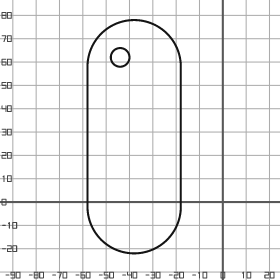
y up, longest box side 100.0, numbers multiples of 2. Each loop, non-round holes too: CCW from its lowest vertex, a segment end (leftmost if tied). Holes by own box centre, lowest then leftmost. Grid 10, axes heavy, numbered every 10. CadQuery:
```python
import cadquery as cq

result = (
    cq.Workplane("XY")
    .moveTo(-58.0, -2.0)
    .threePointArc((-38.0, -22.0), (-18.0, -2.0))
    .lineTo(-18.0, 58.0)
    .threePointArc((-38.0, 78.0), (-58.0, 58.0))
    .close()
    .moveTo(-44.0, 62.0)
    .circle(4.0)
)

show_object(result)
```